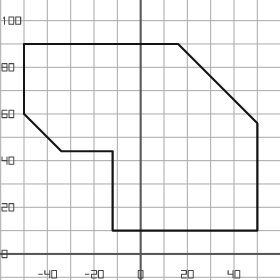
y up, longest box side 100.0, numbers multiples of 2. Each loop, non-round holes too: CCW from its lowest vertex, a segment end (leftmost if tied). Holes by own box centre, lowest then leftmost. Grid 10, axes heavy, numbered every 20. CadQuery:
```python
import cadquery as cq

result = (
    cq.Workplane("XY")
    .moveTo(-12.0, 10.0)
    .lineTo(50.0, 10.0)
    .lineTo(50.0, 56.0)
    .lineTo(16.0, 90.0)
    .lineTo(-50.0, 90.0)
    .lineTo(-50.0, 60.0)
    .lineTo(-34.0, 44.0)
    .lineTo(-12.0, 44.0)
    .close()
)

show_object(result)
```